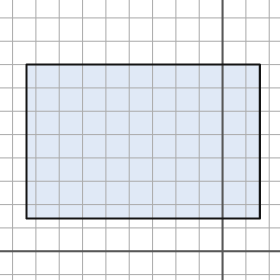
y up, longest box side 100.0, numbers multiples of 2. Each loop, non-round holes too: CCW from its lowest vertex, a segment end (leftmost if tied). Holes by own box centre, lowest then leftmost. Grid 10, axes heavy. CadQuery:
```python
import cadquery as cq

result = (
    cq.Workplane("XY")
    .moveTo(-84.0, 14.0)
    .lineTo(16.0, 14.0)
    .lineTo(16.0, 80.0)
    .lineTo(-84.0, 80.0)
    .close()
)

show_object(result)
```